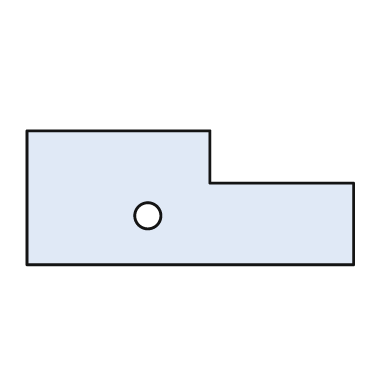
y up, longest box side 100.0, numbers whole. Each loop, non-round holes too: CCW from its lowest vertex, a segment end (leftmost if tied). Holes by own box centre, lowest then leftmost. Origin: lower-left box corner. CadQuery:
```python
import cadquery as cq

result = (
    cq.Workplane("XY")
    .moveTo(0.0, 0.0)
    .lineTo(100.0, 0.0)
    .lineTo(100.0, 25.0)
    .lineTo(56.0, 25.0)
    .lineTo(56.0, 41.0)
    .lineTo(0.0, 41.0)
    .close()
    .moveTo(37.0, 15.0)
    .circle(4.0)
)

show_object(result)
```